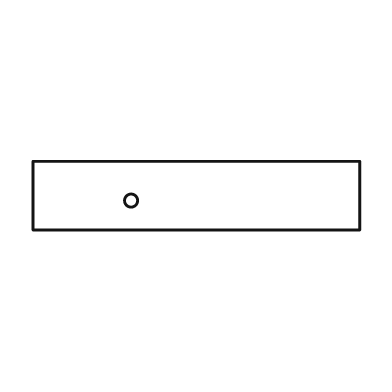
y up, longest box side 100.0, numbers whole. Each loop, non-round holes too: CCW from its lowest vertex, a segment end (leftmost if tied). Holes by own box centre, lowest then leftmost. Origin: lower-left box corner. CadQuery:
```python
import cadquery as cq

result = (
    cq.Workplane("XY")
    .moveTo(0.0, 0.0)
    .lineTo(100.0, 0.0)
    .lineTo(100.0, 21.0)
    .lineTo(0.0, 21.0)
    .close()
    .moveTo(30.0, 9.0)
    .circle(2.0)
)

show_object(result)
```